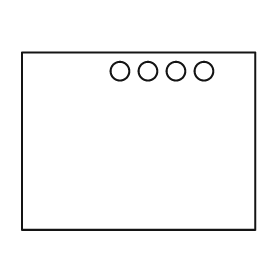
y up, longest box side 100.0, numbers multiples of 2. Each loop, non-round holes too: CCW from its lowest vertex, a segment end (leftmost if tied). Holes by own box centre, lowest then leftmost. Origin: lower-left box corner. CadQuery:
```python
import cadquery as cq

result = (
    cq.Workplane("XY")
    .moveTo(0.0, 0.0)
    .lineTo(100.0, 0.0)
    .lineTo(100.0, 76.0)
    .lineTo(0.0, 76.0)
    .close()
    .moveTo(42.0, 68.0)
    .circle(4.0)
    .moveTo(54.0, 68.0)
    .circle(4.0)
    .moveTo(66.0, 68.0)
    .circle(4.0)
    .moveTo(78.0, 68.0)
    .circle(4.0)
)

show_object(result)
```